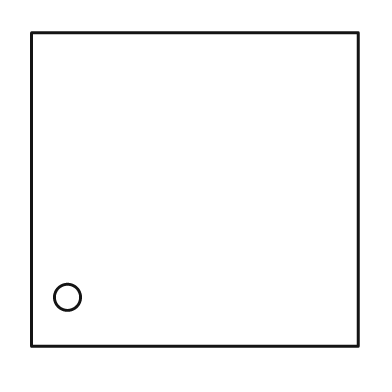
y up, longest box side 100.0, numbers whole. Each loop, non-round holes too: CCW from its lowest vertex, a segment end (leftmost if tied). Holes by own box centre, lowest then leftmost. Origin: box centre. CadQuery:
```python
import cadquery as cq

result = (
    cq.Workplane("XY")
    .moveTo(-50.0, -48.0)
    .lineTo(50.0, -48.0)
    .lineTo(50.0, 48.0)
    .lineTo(-50.0, 48.0)
    .close()
    .moveTo(-39.0, -33.0)
    .circle(4.0)
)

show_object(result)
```